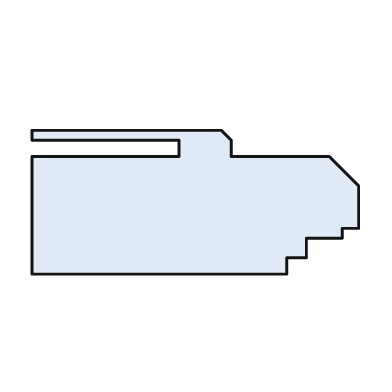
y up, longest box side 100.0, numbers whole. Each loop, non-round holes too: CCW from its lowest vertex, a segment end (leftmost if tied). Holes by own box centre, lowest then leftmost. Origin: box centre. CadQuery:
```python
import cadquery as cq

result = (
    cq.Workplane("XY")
    .moveTo(-50.0, -22.0)
    .lineTo(28.0, -22.0)
    .lineTo(28.0, -17.0)
    .lineTo(34.0, -17.0)
    .lineTo(34.0, -11.0)
    .lineTo(45.0, -11.0)
    .lineTo(45.0, -8.0)
    .lineTo(50.0, -8.0)
    .lineTo(50.0, 5.0)
    .lineTo(41.0, 14.0)
    .lineTo(11.0, 14.0)
    .lineTo(11.0, 19.0)
    .lineTo(8.0, 22.0)
    .lineTo(-50.0, 22.0)
    .lineTo(-50.0, 19.0)
    .lineTo(-5.0, 19.0)
    .lineTo(-5.0, 14.0)
    .lineTo(-50.0, 14.0)
    .close()
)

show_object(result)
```